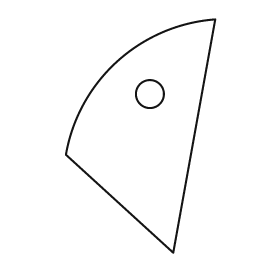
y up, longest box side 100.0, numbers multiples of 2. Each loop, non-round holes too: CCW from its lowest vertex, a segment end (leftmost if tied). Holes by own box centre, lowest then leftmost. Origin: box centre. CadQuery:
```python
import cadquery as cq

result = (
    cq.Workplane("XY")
    .moveTo(14.0, -50.0)
    .lineTo(32.0, 50.0)
    .threePointArc((-10.0, 32.0), (-32.0, -8.0))
    .close()
    .moveTo(4.0, 18.0)
    .circle(6.0)
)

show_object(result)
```